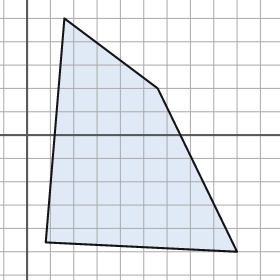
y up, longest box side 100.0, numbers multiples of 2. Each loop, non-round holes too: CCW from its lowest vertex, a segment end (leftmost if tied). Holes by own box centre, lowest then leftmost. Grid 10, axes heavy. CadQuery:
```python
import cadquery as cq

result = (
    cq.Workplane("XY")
    .moveTo(90.0, -50.0)
    .lineTo(56.0, 20.0)
    .lineTo(16.0, 50.0)
    .lineTo(8.0, -46.0)
    .close()
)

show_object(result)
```